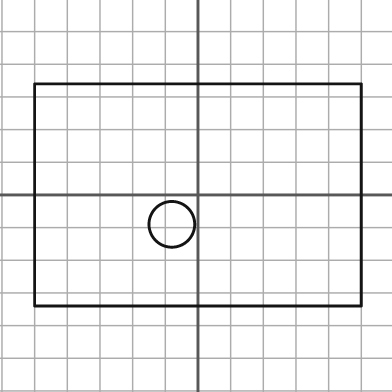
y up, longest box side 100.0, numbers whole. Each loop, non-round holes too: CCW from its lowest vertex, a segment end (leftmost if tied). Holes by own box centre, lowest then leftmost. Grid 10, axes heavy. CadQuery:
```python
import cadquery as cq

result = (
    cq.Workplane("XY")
    .moveTo(-50.0, -34.0)
    .lineTo(50.0, -34.0)
    .lineTo(50.0, 34.0)
    .lineTo(-50.0, 34.0)
    .close()
    .moveTo(-8.0, -9.0)
    .circle(7.0)
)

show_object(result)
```